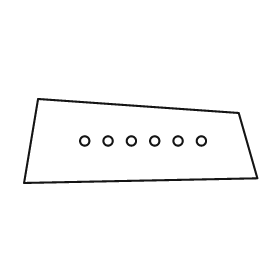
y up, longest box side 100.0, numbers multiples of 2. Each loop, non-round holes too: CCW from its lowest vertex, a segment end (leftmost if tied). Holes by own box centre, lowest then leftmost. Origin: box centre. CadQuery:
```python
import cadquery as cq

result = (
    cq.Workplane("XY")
    .moveTo(-50.0, -18.0)
    .lineTo(50.0, -16.0)
    .lineTo(42.0, 12.0)
    .lineTo(-44.0, 18.0)
    .close()
    .moveTo(-24.0, 0.0)
    .circle(2.0)
    .moveTo(-14.0, 0.0)
    .circle(2.0)
    .moveTo(-4.0, 0.0)
    .circle(2.0)
    .moveTo(6.0, 0.0)
    .circle(2.0)
    .moveTo(16.0, 0.0)
    .circle(2.0)
    .moveTo(26.0, 0.0)
    .circle(2.0)
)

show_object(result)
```